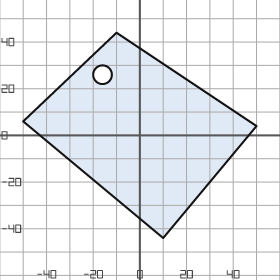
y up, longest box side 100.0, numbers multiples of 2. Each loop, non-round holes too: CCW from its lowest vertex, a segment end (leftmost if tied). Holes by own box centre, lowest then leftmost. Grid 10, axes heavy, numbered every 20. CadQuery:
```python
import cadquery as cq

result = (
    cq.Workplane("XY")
    .moveTo(10.0, -44.0)
    .lineTo(50.0, 4.0)
    .lineTo(-10.0, 44.0)
    .lineTo(-50.0, 6.0)
    .close()
    .moveTo(-16.0, 26.0)
    .circle(4.0)
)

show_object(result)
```